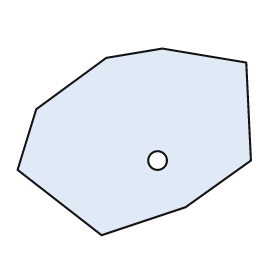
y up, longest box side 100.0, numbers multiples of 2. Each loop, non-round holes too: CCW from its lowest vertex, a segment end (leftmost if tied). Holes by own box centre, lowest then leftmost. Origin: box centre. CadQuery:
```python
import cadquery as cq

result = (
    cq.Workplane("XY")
    .moveTo(-14.0, -40.0)
    .lineTo(22.0, -28.0)
    .lineTo(50.0, -8.0)
    .lineTo(48.0, 34.0)
    .lineTo(12.0, 40.0)
    .lineTo(-12.0, 36.0)
    .lineTo(-42.0, 14.0)
    .lineTo(-50.0, -12.0)
    .close()
    .moveTo(10.0, -8.0)
    .circle(4.0)
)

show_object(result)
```